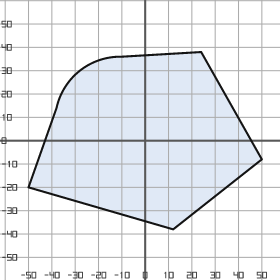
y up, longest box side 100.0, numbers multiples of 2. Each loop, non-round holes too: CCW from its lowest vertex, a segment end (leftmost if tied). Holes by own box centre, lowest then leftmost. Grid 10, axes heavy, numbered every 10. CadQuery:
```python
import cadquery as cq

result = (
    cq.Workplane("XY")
    .moveTo(12.0, -38.0)
    .lineTo(50.0, -8.0)
    .lineTo(24.0, 38.0)
    .lineTo(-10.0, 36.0)
    .threePointArc((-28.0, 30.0), (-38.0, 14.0))
    .lineTo(-50.0, -20.0)
    .close()
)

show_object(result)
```